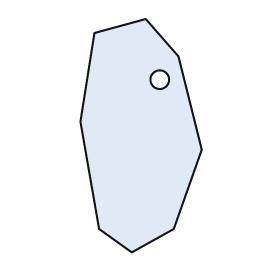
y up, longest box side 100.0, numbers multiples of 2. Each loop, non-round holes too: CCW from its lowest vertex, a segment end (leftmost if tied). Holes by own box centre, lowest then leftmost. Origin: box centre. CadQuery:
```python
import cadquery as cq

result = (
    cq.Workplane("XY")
    .moveTo(-4.0, -50.0)
    .lineTo(14.0, -40.0)
    .lineTo(26.0, -6.0)
    .lineTo(16.0, 34.0)
    .lineTo(2.0, 50.0)
    .lineTo(-20.0, 44.0)
    .lineTo(-26.0, 6.0)
    .lineTo(-18.0, -40.0)
    .close()
    .moveTo(8.0, 24.0)
    .circle(4.0)
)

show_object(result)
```